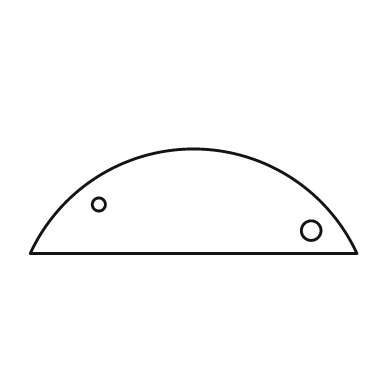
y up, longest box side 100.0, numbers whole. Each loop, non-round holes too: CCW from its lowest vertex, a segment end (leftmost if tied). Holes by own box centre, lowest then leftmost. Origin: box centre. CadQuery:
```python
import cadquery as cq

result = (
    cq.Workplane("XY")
    .moveTo(-50.0, -16.0)
    .lineTo(50.0, -16.0)
    .threePointArc((0.0, 16.0), (-50.0, -16.0))
    .close()
    .moveTo(36.0, -9.0)
    .circle(3.0)
    .moveTo(-29.0, -1.0)
    .circle(2.0)
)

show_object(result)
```